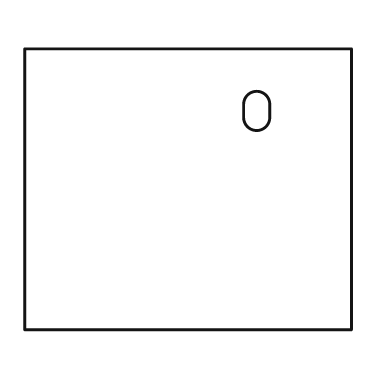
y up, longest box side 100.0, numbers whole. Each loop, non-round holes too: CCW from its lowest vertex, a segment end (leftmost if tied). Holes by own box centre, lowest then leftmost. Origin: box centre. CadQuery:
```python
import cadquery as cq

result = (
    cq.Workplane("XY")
    .moveTo(-50.0, -43.0)
    .lineTo(50.0, -43.0)
    .lineTo(50.0, 43.0)
    .lineTo(-50.0, 43.0)
    .close()
    .moveTo(17.0, 22.0)
    .threePointArc((21.0, 18.0), (25.0, 22.0))
    .lineTo(25.0, 26.0)
    .threePointArc((21.0, 30.0), (17.0, 26.0))
    .close()
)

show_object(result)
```